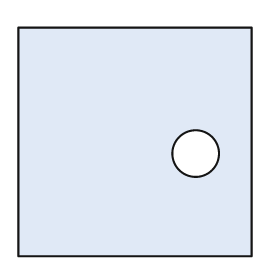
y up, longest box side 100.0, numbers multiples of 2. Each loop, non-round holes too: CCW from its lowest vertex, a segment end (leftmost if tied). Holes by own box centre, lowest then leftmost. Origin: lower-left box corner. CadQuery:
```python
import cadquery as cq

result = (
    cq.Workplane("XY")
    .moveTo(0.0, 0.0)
    .lineTo(100.0, 0.0)
    .lineTo(100.0, 98.0)
    .lineTo(0.0, 98.0)
    .close()
    .moveTo(76.0, 44.0)
    .circle(10.0)
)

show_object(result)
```